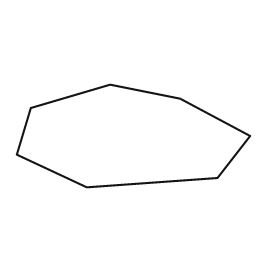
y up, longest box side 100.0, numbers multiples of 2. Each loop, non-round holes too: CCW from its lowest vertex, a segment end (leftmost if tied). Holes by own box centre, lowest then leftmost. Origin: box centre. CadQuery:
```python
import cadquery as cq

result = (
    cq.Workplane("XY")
    .moveTo(-20.0, -22.0)
    .lineTo(36.0, -18.0)
    .lineTo(50.0, 0.0)
    .lineTo(20.0, 16.0)
    .lineTo(-10.0, 22.0)
    .lineTo(-44.0, 12.0)
    .lineTo(-50.0, -8.0)
    .close()
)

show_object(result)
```